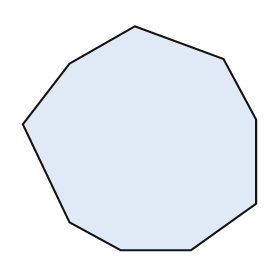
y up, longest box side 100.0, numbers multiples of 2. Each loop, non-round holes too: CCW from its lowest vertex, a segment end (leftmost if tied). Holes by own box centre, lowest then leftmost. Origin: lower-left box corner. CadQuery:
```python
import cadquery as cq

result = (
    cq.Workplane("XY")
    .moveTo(42.0, 0.0)
    .lineTo(72.0, 0.0)
    .lineTo(100.0, 20.0)
    .lineTo(100.0, 56.0)
    .lineTo(86.0, 82.0)
    .lineTo(48.0, 96.0)
    .lineTo(20.0, 80.0)
    .lineTo(0.0, 54.0)
    .lineTo(20.0, 12.0)
    .close()
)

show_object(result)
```